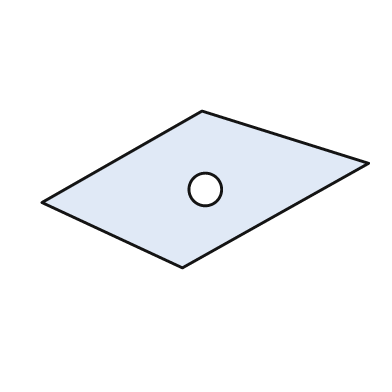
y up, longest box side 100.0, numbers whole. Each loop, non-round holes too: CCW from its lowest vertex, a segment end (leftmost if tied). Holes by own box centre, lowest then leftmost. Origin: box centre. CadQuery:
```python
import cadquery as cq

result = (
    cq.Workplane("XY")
    .moveTo(-7.0, -24.0)
    .lineTo(50.0, 8.0)
    .lineTo(-1.0, 24.0)
    .lineTo(-50.0, -4.0)
    .close()
    .moveTo(0.0, 0.0)
    .circle(5.0)
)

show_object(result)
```